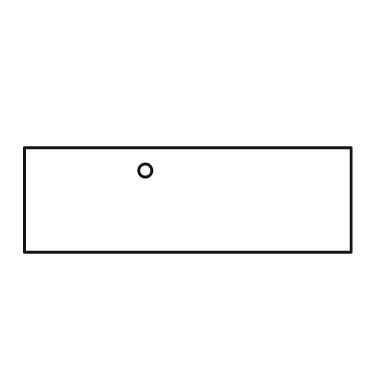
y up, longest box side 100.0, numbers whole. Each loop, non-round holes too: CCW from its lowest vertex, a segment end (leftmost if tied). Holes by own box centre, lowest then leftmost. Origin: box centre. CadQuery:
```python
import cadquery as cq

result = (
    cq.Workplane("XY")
    .moveTo(-50.0, -16.0)
    .lineTo(50.0, -16.0)
    .lineTo(50.0, 16.0)
    .lineTo(-50.0, 16.0)
    .close()
    .moveTo(-13.0, 9.0)
    .circle(2.0)
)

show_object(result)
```